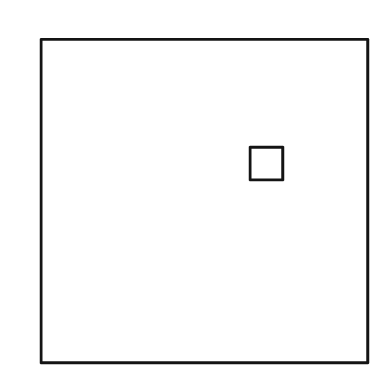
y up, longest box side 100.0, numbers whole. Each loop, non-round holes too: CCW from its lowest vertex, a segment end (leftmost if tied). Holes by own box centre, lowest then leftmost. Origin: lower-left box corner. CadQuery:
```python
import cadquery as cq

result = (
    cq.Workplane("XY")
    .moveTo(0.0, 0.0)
    .lineTo(100.0, 0.0)
    .lineTo(100.0, 99.0)
    .lineTo(0.0, 99.0)
    .close()
    .moveTo(64.0, 56.0)
    .lineTo(74.0, 56.0)
    .lineTo(74.0, 66.0)
    .lineTo(64.0, 66.0)
    .close()
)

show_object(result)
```